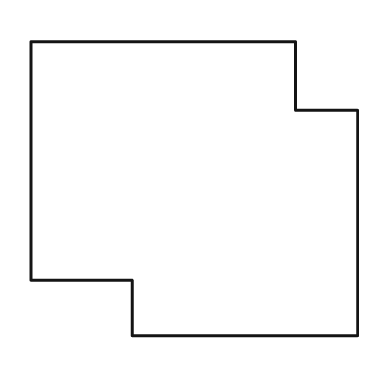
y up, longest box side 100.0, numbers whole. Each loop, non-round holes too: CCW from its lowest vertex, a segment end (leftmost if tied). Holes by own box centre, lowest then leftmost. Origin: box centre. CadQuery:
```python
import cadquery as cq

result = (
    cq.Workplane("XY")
    .moveTo(-19.0, -45.0)
    .lineTo(50.0, -45.0)
    .lineTo(50.0, 24.0)
    .lineTo(31.0, 24.0)
    .lineTo(31.0, 45.0)
    .lineTo(-50.0, 45.0)
    .lineTo(-50.0, -28.0)
    .lineTo(-19.0, -28.0)
    .close()
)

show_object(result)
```